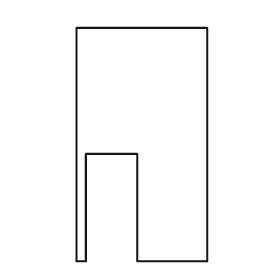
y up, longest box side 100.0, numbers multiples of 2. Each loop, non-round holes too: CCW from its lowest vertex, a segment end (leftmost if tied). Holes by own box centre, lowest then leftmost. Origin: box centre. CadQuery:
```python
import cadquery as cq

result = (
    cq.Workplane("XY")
    .moveTo(-28.0, -50.0)
    .lineTo(-24.0, -50.0)
    .lineTo(-24.0, -4.0)
    .lineTo(-2.0, -4.0)
    .lineTo(-2.0, -50.0)
    .lineTo(28.0, -50.0)
    .lineTo(28.0, 50.0)
    .lineTo(-28.0, 50.0)
    .close()
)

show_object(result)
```